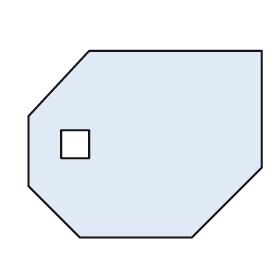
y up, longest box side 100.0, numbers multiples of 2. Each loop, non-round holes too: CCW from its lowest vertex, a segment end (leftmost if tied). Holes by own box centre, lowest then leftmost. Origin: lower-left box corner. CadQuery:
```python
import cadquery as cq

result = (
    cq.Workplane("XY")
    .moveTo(22.0, 0.0)
    .lineTo(70.0, 0.0)
    .lineTo(100.0, 30.0)
    .lineTo(100.0, 80.0)
    .lineTo(26.0, 80.0)
    .lineTo(0.0, 52.0)
    .lineTo(0.0, 22.0)
    .close()
    .moveTo(14.0, 34.0)
    .lineTo(26.0, 34.0)
    .lineTo(26.0, 46.0)
    .lineTo(14.0, 46.0)
    .close()
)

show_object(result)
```